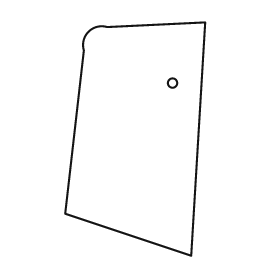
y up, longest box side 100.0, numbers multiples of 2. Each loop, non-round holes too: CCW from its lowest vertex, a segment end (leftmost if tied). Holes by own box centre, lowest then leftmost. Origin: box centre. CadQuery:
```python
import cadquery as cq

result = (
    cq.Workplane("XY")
    .moveTo(24.0, -50.0)
    .lineTo(30.0, 50.0)
    .lineTo(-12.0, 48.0)
    .threePointArc((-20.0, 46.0), (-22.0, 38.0))
    .lineTo(-30.0, -32.0)
    .close()
    .moveTo(16.0, 24.0)
    .circle(2.0)
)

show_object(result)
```